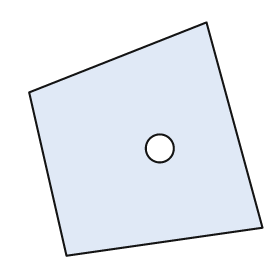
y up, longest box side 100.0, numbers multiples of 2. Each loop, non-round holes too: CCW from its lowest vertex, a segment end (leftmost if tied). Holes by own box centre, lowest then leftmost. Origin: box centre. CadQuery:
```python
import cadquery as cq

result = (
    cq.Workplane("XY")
    .moveTo(-34.0, -50.0)
    .lineTo(50.0, -38.0)
    .lineTo(26.0, 50.0)
    .lineTo(-50.0, 20.0)
    .close()
    .moveTo(6.0, -4.0)
    .circle(6.0)
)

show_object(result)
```